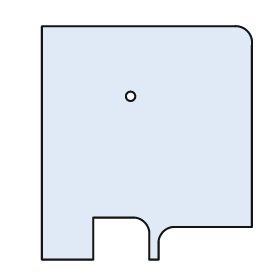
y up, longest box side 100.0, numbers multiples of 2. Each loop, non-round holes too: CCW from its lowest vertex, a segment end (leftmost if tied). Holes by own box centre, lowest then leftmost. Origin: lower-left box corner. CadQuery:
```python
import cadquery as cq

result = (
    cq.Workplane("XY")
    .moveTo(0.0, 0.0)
    .lineTo(22.0, 0.0)
    .lineTo(22.0, 18.0)
    .lineTo(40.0, 18.0)
    .threePointArc((44.0, 16.0), (46.0, 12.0))
    .lineTo(46.0, 0.0)
    .lineTo(50.0, 0.0)
    .lineTo(50.0, 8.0)
    .threePointArc((52.0, 12.0), (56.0, 14.0))
    .lineTo(90.0, 14.0)
    .lineTo(90.0, 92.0)
    .threePointArc((88.0, 98.0), (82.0, 100.0))
    .lineTo(0.0, 100.0)
    .close()
    .moveTo(38.0, 70.0)
    .circle(2.0)
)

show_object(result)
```